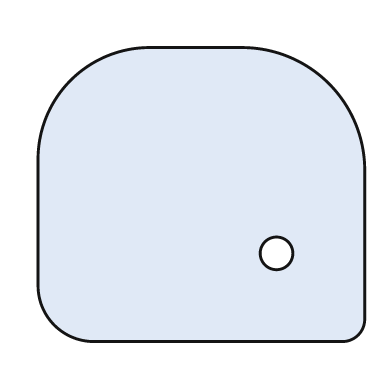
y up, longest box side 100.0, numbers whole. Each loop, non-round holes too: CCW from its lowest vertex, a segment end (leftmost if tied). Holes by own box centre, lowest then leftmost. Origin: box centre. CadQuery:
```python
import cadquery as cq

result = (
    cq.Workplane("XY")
    .moveTo(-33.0, -45.0)
    .lineTo(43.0, -45.0)
    .threePointArc((48.0, -43.0), (50.0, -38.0))
    .lineTo(50.0, 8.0)
    .threePointArc((39.0, 34.0), (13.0, 45.0))
    .lineTo(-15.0, 45.0)
    .threePointArc((-40.0, 35.0), (-50.0, 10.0))
    .lineTo(-50.0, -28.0)
    .threePointArc((-45.0, -40.0), (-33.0, -45.0))
    .close()
    .moveTo(23.0, -18.0)
    .circle(5.0)
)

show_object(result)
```